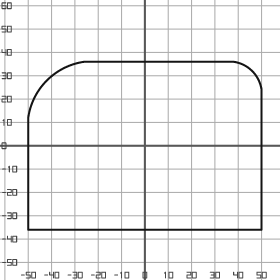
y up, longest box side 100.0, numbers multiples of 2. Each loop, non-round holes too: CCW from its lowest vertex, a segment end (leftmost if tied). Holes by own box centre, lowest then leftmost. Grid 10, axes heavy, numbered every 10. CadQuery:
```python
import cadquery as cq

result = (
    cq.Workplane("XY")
    .moveTo(-50.0, -36.0)
    .lineTo(50.0, -36.0)
    .lineTo(50.0, 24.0)
    .threePointArc((46.0, 32.0), (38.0, 36.0))
    .lineTo(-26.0, 36.0)
    .threePointArc((-42.0, 28.0), (-50.0, 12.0))
    .close()
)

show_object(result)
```